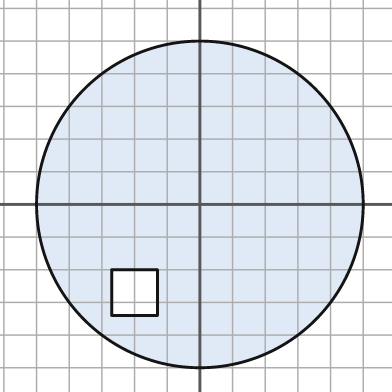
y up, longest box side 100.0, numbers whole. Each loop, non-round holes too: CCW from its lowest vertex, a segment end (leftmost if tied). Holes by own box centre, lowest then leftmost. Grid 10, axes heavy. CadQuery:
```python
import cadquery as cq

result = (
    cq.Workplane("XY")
    .moveTo(0.0, 0.0)
    .circle(50.0)
    .moveTo(-27.0, -34.0)
    .lineTo(-13.0, -34.0)
    .lineTo(-13.0, -20.0)
    .lineTo(-27.0, -20.0)
    .close()
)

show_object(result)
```